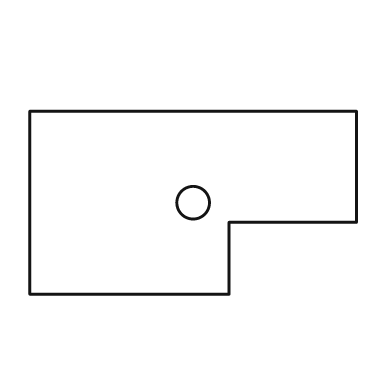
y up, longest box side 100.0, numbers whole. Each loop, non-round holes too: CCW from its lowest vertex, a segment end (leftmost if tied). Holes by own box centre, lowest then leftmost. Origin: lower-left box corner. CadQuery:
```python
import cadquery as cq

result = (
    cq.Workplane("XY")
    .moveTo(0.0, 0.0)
    .lineTo(61.0, 0.0)
    .lineTo(61.0, 22.0)
    .lineTo(100.0, 22.0)
    .lineTo(100.0, 56.0)
    .lineTo(0.0, 56.0)
    .close()
    .moveTo(50.0, 28.0)
    .circle(5.0)
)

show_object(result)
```